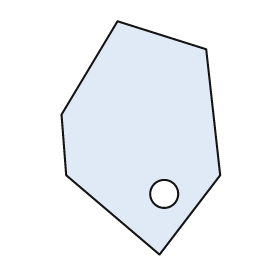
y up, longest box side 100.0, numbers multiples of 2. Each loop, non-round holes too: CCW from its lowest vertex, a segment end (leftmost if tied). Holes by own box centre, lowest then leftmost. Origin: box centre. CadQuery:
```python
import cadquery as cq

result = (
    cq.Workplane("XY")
    .moveTo(8.0, -50.0)
    .lineTo(34.0, -16.0)
    .lineTo(28.0, 38.0)
    .lineTo(-10.0, 50.0)
    .lineTo(-34.0, 10.0)
    .lineTo(-32.0, -16.0)
    .close()
    .moveTo(10.0, -24.0)
    .circle(6.0)
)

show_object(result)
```